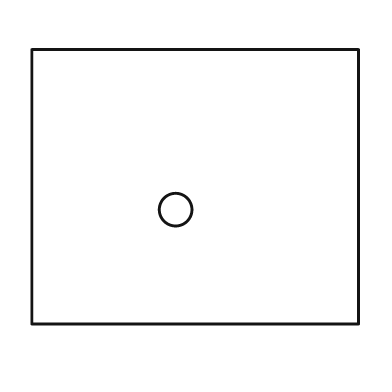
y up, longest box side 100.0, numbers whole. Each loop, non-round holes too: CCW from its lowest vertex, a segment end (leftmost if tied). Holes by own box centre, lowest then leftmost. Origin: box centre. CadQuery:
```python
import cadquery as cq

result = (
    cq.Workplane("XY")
    .moveTo(-50.0, -42.0)
    .lineTo(50.0, -42.0)
    .lineTo(50.0, 42.0)
    .lineTo(-50.0, 42.0)
    .close()
    .moveTo(-6.0, -7.0)
    .circle(5.0)
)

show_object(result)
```